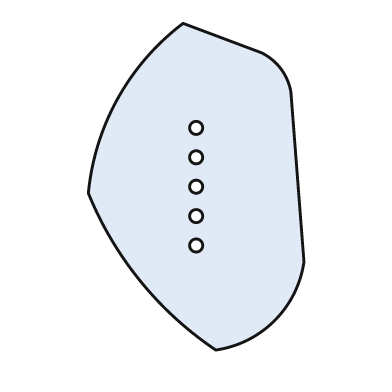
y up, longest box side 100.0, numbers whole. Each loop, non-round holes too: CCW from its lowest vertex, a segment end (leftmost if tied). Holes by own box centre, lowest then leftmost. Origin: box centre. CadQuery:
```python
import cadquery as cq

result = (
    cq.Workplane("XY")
    .moveTo(6.0, -50.0)
    .threePointArc((24.0, -41.0), (33.0, -23.0))
    .lineTo(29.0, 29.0)
    .threePointArc((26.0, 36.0), (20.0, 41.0))
    .lineTo(-4.0, 50.0)
    .threePointArc((-24.0, 27.0), (-33.0, -2.0))
    .threePointArc((-17.0, -29.0), (6.0, -50.0))
    .close()
    .moveTo(0.0, -18.0)
    .circle(2.0)
    .moveTo(0.0, -9.0)
    .circle(2.0)
    .moveTo(0.0, 0.0)
    .circle(2.0)
    .moveTo(0.0, 9.0)
    .circle(2.0)
    .moveTo(0.0, 18.0)
    .circle(2.0)
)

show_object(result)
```